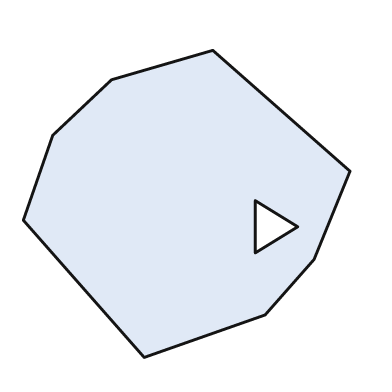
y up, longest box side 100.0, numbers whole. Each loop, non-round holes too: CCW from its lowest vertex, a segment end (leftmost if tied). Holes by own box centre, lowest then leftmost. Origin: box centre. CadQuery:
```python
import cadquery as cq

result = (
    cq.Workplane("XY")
    .moveTo(-13.0, -47.0)
    .lineTo(24.0, -34.0)
    .lineTo(39.0, -17.0)
    .lineTo(50.0, 10.0)
    .lineTo(8.0, 47.0)
    .lineTo(-23.0, 38.0)
    .lineTo(-41.0, 21.0)
    .lineTo(-50.0, -5.0)
    .close()
    .moveTo(21.0, -15.0)
    .lineTo(34.0, -7.0)
    .lineTo(21.0, 1.0)
    .close()
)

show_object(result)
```